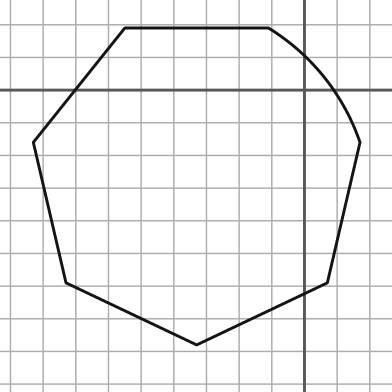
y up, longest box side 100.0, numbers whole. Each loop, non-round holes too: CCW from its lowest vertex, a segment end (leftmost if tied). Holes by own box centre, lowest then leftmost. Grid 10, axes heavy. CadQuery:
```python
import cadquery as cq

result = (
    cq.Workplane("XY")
    .moveTo(-33.0, -78.0)
    .lineTo(7.0, -59.0)
    .lineTo(17.0, -16.0)
    .threePointArc((6.0, 4.0), (-11.0, 19.0))
    .lineTo(-55.0, 19.0)
    .lineTo(-83.0, -16.0)
    .lineTo(-73.0, -59.0)
    .close()
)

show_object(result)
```